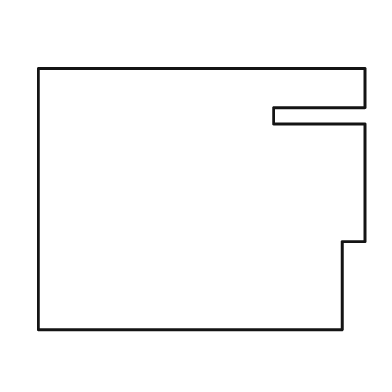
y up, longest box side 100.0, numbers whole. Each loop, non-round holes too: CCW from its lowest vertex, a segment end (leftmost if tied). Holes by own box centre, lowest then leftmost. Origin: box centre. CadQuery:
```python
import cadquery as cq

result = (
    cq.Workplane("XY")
    .moveTo(-50.0, -40.0)
    .lineTo(43.0, -40.0)
    .lineTo(43.0, -13.0)
    .lineTo(50.0, -13.0)
    .lineTo(50.0, 23.0)
    .lineTo(22.0, 23.0)
    .lineTo(22.0, 28.0)
    .lineTo(50.0, 28.0)
    .lineTo(50.0, 40.0)
    .lineTo(-50.0, 40.0)
    .close()
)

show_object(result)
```